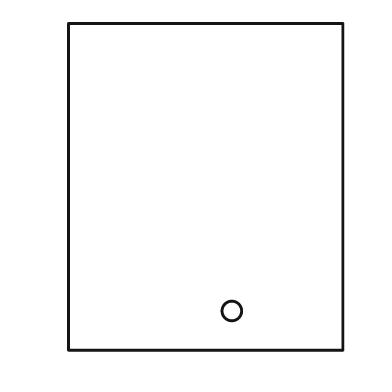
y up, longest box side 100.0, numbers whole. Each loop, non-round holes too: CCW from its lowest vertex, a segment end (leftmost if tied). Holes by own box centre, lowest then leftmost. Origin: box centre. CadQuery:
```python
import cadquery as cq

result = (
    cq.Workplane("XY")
    .moveTo(-42.0, -50.0)
    .lineTo(42.0, -50.0)
    .lineTo(42.0, 50.0)
    .lineTo(-42.0, 50.0)
    .close()
    .moveTo(8.0, -38.0)
    .circle(3.0)
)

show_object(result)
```